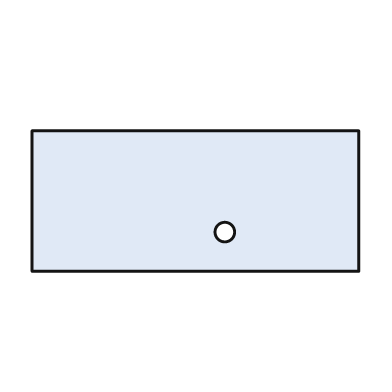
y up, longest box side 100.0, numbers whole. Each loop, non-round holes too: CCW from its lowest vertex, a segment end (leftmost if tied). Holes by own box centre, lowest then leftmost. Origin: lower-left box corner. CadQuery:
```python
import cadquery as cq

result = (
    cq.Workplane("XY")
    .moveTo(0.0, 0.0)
    .lineTo(100.0, 0.0)
    .lineTo(100.0, 43.0)
    .lineTo(0.0, 43.0)
    .close()
    .moveTo(59.0, 12.0)
    .circle(3.0)
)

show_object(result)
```